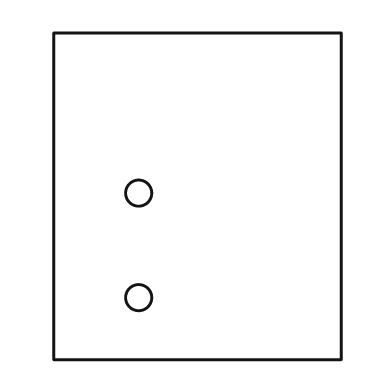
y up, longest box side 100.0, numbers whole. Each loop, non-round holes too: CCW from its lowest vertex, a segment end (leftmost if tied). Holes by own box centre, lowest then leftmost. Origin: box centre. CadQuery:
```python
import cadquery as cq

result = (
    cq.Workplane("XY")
    .moveTo(-44.0, -50.0)
    .lineTo(44.0, -50.0)
    .lineTo(44.0, 50.0)
    .lineTo(-44.0, 50.0)
    .close()
    .moveTo(-18.0, -31.0)
    .circle(4.0)
    .moveTo(-18.0, 1.0)
    .circle(4.0)
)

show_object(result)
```